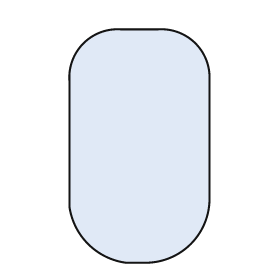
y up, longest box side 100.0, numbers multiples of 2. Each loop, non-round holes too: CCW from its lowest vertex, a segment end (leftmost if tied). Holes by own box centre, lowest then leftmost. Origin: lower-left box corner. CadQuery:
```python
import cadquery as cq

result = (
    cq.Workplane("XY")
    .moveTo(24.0, 0.0)
    .lineTo(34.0, 0.0)
    .threePointArc((52.0, 8.0), (60.0, 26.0))
    .lineTo(60.0, 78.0)
    .threePointArc((54.0, 94.0), (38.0, 100.0))
    .lineTo(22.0, 100.0)
    .threePointArc((6.0, 94.0), (0.0, 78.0))
    .lineTo(0.0, 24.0)
    .threePointArc((8.0, 8.0), (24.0, 0.0))
    .close()
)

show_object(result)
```